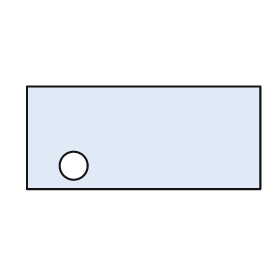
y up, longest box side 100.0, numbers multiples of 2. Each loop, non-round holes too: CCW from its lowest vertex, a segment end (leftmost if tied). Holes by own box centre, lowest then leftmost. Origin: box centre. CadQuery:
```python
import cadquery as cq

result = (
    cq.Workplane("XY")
    .moveTo(-50.0, -22.0)
    .lineTo(50.0, -22.0)
    .lineTo(50.0, 22.0)
    .lineTo(-50.0, 22.0)
    .close()
    .moveTo(-30.0, -12.0)
    .circle(6.0)
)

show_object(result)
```